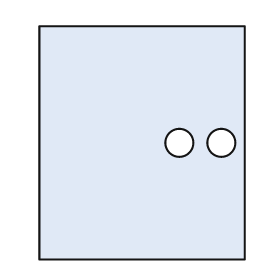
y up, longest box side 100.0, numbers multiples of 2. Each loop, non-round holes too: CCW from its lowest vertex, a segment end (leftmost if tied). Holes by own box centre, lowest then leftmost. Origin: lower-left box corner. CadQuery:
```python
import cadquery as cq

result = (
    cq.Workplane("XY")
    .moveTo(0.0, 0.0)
    .lineTo(88.0, 0.0)
    .lineTo(88.0, 100.0)
    .lineTo(0.0, 100.0)
    .close()
    .moveTo(60.0, 50.0)
    .circle(6.0)
    .moveTo(78.0, 50.0)
    .circle(6.0)
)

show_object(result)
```